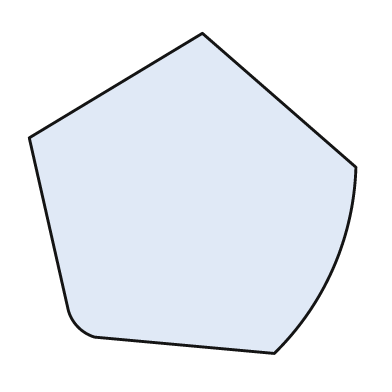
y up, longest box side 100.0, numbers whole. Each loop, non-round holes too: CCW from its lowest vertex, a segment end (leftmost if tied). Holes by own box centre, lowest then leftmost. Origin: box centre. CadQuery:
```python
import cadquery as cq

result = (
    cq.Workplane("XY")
    .moveTo(25.0, -49.0)
    .threePointArc((43.0, -23.0), (50.0, 8.0))
    .lineTo(3.0, 49.0)
    .lineTo(-50.0, 17.0)
    .lineTo(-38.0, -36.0)
    .threePointArc((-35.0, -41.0), (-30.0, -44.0))
    .close()
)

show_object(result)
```